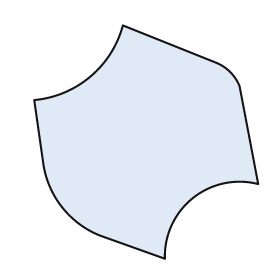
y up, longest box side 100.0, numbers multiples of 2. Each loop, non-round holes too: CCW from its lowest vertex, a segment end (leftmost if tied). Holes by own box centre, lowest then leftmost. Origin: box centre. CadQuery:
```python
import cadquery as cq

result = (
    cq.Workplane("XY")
    .moveTo(8.0, -50.0)
    .threePointArc((20.0, -24.0), (48.0, -18.0))
    .lineTo(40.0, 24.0)
    .threePointArc((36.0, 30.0), (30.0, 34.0))
    .lineTo(-10.0, 50.0)
    .threePointArc((-24.0, 28.0), (-48.0, 18.0))
    .lineTo(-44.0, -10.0)
    .threePointArc((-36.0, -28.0), (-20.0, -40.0))
    .close()
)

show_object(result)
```